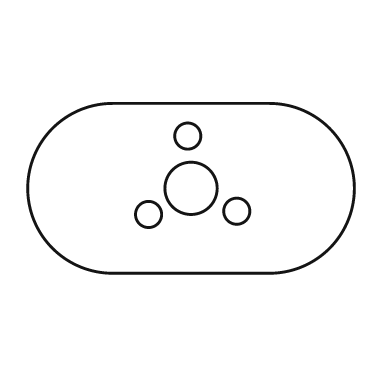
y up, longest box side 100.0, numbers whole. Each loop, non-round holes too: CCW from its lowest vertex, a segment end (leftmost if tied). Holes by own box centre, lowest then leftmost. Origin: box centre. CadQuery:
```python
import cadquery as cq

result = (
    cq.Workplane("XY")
    .moveTo(-24.0, -26.0)
    .lineTo(24.0, -26.0)
    .threePointArc((50.0, 0.0), (24.0, 26.0))
    .lineTo(-24.0, 26.0)
    .threePointArc((-50.0, 0.0), (-24.0, -26.0))
    .close()
    .moveTo(-13.0, -8.0)
    .circle(4.0)
    .moveTo(14.0, -7.0)
    .circle(4.0)
    .moveTo(0.0, 0.0)
    .circle(8.0)
    .moveTo(-1.0, 16.0)
    .circle(4.0)
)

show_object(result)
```